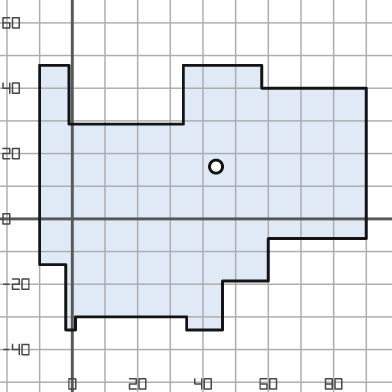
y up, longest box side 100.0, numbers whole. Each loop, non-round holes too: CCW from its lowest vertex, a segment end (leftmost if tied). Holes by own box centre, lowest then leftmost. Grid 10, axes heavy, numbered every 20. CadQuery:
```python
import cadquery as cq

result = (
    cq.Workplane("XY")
    .moveTo(-2.0, -34.0)
    .lineTo(1.0, -34.0)
    .lineTo(1.0, -30.0)
    .lineTo(35.0, -30.0)
    .lineTo(35.0, -34.0)
    .lineTo(46.0, -34.0)
    .lineTo(46.0, -19.0)
    .lineTo(60.0, -19.0)
    .lineTo(60.0, -6.0)
    .lineTo(90.0, -6.0)
    .lineTo(90.0, 40.0)
    .lineTo(58.0, 40.0)
    .lineTo(58.0, 47.0)
    .lineTo(34.0, 47.0)
    .lineTo(34.0, 29.0)
    .lineTo(-1.0, 29.0)
    .lineTo(-1.0, 47.0)
    .lineTo(-10.0, 47.0)
    .lineTo(-10.0, -14.0)
    .lineTo(-2.0, -14.0)
    .close()
    .moveTo(44.0, 16.0)
    .circle(2.0)
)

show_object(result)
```